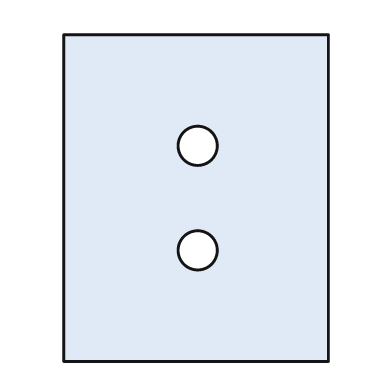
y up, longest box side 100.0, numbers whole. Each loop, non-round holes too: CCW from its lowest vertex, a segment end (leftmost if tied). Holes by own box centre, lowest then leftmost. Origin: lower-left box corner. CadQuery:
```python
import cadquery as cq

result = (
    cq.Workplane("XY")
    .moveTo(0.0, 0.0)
    .lineTo(81.0, 0.0)
    .lineTo(81.0, 100.0)
    .lineTo(0.0, 100.0)
    .close()
    .moveTo(41.0, 34.0)
    .circle(6.0)
    .moveTo(41.0, 66.0)
    .circle(6.0)
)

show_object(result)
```